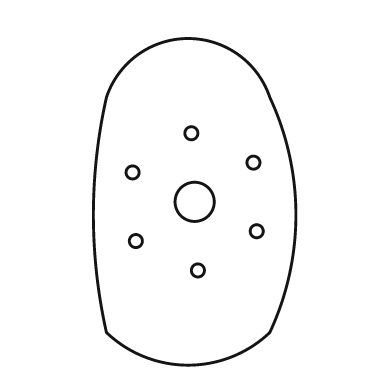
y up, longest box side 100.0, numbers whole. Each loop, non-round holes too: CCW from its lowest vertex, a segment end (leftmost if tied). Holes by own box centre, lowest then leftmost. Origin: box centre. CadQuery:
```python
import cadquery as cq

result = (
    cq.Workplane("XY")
    .moveTo(-27.0, -40.0)
    .threePointArc((-2.0, -50.0), (23.0, -40.0))
    .threePointArc((31.0, -4.0), (23.0, 32.0))
    .threePointArc((-2.0, 50.0), (-27.0, 32.0))
    .threePointArc((-31.0, -4.0), (-27.0, -40.0))
    .close()
    .moveTo(1.0, -21.0)
    .circle(2.0)
    .moveTo(-18.0, -12.0)
    .circle(2.0)
    .moveTo(19.0, -9.0)
    .circle(2.0)
    .moveTo(0.0, 0.0)
    .circle(6.0)
    .moveTo(-19.0, 9.0)
    .circle(2.0)
    .moveTo(18.0, 12.0)
    .circle(2.0)
    .moveTo(-1.0, 21.0)
    .circle(2.0)
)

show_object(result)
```